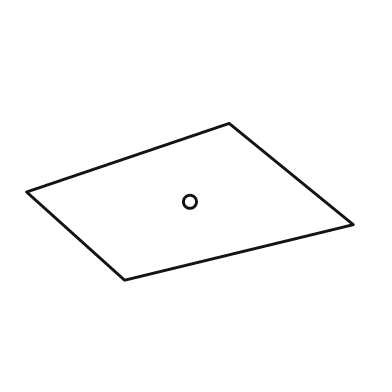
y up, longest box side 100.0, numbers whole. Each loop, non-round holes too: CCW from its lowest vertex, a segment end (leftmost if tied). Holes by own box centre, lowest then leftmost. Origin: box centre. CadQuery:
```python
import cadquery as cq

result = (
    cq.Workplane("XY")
    .moveTo(-20.0, -24.0)
    .lineTo(50.0, -7.0)
    .lineTo(12.0, 24.0)
    .lineTo(-50.0, 3.0)
    .close()
    .moveTo(0.0, 0.0)
    .circle(2.0)
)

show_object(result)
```